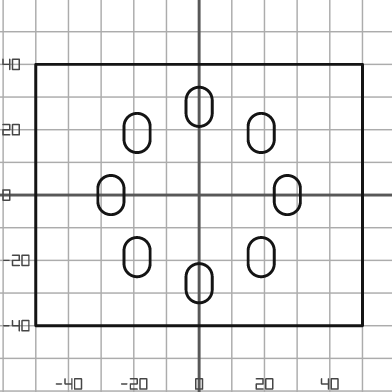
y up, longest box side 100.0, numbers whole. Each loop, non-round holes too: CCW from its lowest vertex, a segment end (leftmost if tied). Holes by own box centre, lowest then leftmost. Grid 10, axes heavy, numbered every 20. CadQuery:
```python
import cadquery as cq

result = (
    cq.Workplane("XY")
    .moveTo(-50.0, -40.0)
    .lineTo(50.0, -40.0)
    .lineTo(50.0, 40.0)
    .lineTo(-50.0, 40.0)
    .close()
    .moveTo(-4.0, -29.0)
    .threePointArc((0.0, -33.0), (4.0, -29.0))
    .lineTo(4.0, -25.0)
    .threePointArc((0.0, -21.0), (-4.0, -25.0))
    .close()
    .moveTo(-23.0, -21.0)
    .threePointArc((-19.0, -25.0), (-15.0, -21.0))
    .lineTo(-15.0, -17.0)
    .threePointArc((-19.0, -13.0), (-23.0, -17.0))
    .close()
    .moveTo(15.0, -21.0)
    .threePointArc((19.0, -25.0), (23.0, -21.0))
    .lineTo(23.0, -17.0)
    .threePointArc((19.0, -13.0), (15.0, -17.0))
    .close()
    .moveTo(-31.0, -2.0)
    .threePointArc((-27.0, -6.0), (-23.0, -2.0))
    .lineTo(-23.0, 2.0)
    .threePointArc((-27.0, 6.0), (-31.0, 2.0))
    .close()
    .moveTo(23.0, -2.0)
    .threePointArc((27.0, -6.0), (31.0, -2.0))
    .lineTo(31.0, 2.0)
    .threePointArc((27.0, 6.0), (23.0, 2.0))
    .close()
    .moveTo(-23.0, 17.0)
    .threePointArc((-19.0, 13.0), (-15.0, 17.0))
    .lineTo(-15.0, 21.0)
    .threePointArc((-19.0, 25.0), (-23.0, 21.0))
    .close()
    .moveTo(15.0, 17.0)
    .threePointArc((19.0, 13.0), (23.0, 17.0))
    .lineTo(23.0, 21.0)
    .threePointArc((19.0, 25.0), (15.0, 21.0))
    .close()
    .moveTo(-4.0, 25.0)
    .threePointArc((0.0, 21.0), (4.0, 25.0))
    .lineTo(4.0, 29.0)
    .threePointArc((0.0, 33.0), (-4.0, 29.0))
    .close()
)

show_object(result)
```